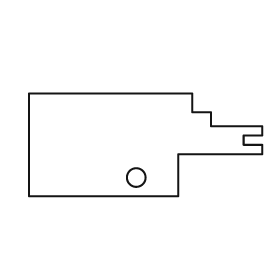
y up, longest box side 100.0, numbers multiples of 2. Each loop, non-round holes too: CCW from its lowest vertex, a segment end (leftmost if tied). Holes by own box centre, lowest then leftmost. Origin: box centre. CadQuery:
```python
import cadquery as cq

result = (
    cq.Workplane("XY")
    .moveTo(-50.0, -22.0)
    .lineTo(14.0, -22.0)
    .lineTo(14.0, -4.0)
    .lineTo(50.0, -4.0)
    .lineTo(50.0, 0.0)
    .lineTo(42.0, 0.0)
    .lineTo(42.0, 4.0)
    .lineTo(50.0, 4.0)
    .lineTo(50.0, 8.0)
    .lineTo(28.0, 8.0)
    .lineTo(28.0, 14.0)
    .lineTo(20.0, 14.0)
    .lineTo(20.0, 22.0)
    .lineTo(-50.0, 22.0)
    .close()
    .moveTo(-4.0, -14.0)
    .circle(4.0)
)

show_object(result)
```